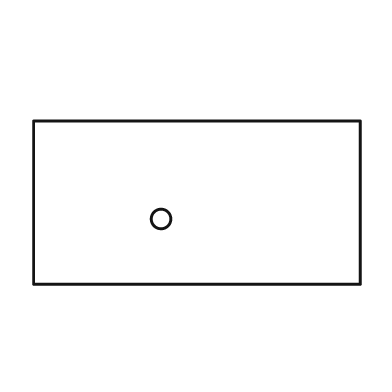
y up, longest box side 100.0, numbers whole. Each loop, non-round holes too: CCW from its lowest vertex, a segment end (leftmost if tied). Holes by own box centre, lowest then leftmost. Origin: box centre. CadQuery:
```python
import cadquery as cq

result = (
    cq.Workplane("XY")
    .moveTo(-50.0, -25.0)
    .lineTo(50.0, -25.0)
    .lineTo(50.0, 25.0)
    .lineTo(-50.0, 25.0)
    .close()
    .moveTo(-11.0, -5.0)
    .circle(3.0)
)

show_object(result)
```